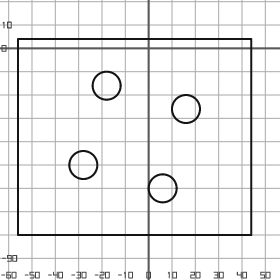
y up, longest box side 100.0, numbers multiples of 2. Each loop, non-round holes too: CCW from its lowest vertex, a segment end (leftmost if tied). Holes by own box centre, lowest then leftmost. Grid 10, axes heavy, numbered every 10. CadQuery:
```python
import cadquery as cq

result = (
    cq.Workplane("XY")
    .moveTo(-56.0, -80.0)
    .lineTo(44.0, -80.0)
    .lineTo(44.0, 4.0)
    .lineTo(-56.0, 4.0)
    .close()
    .moveTo(6.0, -60.0)
    .circle(6.0)
    .moveTo(-28.0, -50.0)
    .circle(6.0)
    .moveTo(16.0, -26.0)
    .circle(6.0)
    .moveTo(-18.0, -16.0)
    .circle(6.0)
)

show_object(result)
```